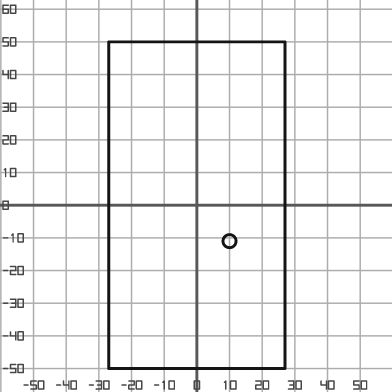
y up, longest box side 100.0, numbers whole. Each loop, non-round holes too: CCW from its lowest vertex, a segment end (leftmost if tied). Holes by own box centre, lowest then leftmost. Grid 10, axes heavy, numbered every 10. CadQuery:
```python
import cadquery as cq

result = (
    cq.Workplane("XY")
    .moveTo(-27.0, -50.0)
    .lineTo(27.0, -50.0)
    .lineTo(27.0, 50.0)
    .lineTo(-27.0, 50.0)
    .close()
    .moveTo(10.0, -11.0)
    .circle(2.0)
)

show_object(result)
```